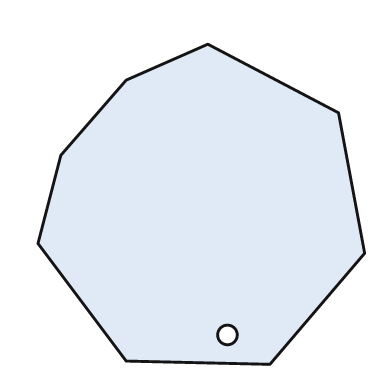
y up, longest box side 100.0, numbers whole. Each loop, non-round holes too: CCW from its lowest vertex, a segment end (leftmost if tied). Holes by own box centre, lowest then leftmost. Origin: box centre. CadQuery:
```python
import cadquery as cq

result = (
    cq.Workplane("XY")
    .moveTo(21.0, -49.0)
    .lineTo(50.0, -15.0)
    .lineTo(42.0, 28.0)
    .lineTo(2.0, 49.0)
    .lineTo(-23.0, 38.0)
    .lineTo(-43.0, 15.0)
    .lineTo(-50.0, -12.0)
    .lineTo(-23.0, -48.0)
    .close()
    .moveTo(8.0, -40.0)
    .circle(3.0)
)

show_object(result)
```